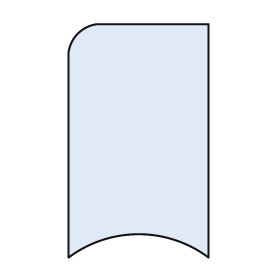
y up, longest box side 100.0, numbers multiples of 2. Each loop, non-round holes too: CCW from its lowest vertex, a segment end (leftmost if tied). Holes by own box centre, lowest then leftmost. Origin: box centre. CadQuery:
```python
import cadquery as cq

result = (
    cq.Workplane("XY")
    .moveTo(-30.0, -50.0)
    .threePointArc((0.0, -40.0), (30.0, -50.0))
    .lineTo(30.0, 50.0)
    .lineTo(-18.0, 50.0)
    .threePointArc((-26.0, 46.0), (-30.0, 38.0))
    .close()
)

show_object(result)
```